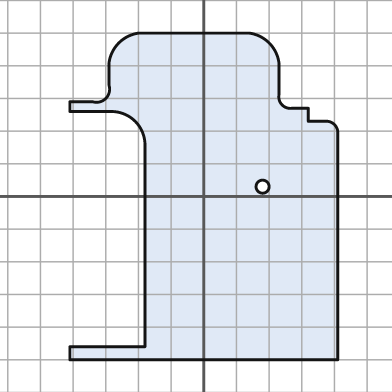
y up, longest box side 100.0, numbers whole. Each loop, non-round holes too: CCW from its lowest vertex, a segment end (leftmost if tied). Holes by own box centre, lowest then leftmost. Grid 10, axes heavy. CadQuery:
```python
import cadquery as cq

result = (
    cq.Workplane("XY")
    .moveTo(-41.0, -50.0)
    .lineTo(41.0, -50.0)
    .lineTo(41.0, 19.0)
    .threePointArc((40.0, 22.0), (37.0, 23.0))
    .lineTo(32.0, 23.0)
    .lineTo(32.0, 27.0)
    .lineTo(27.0, 27.0)
    .threePointArc((24.0, 28.0), (23.0, 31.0))
    .lineTo(23.0, 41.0)
    .threePointArc((20.0, 47.0), (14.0, 50.0))
    .lineTo(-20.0, 50.0)
    .threePointArc((-26.0, 47.0), (-29.0, 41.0))
    .lineTo(-29.0, 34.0)
    .threePointArc((-30.0, 30.0), (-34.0, 29.0))
    .lineTo(-41.0, 29.0)
    .lineTo(-41.0, 26.0)
    .lineTo(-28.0, 26.0)
    .threePointArc((-21.0, 23.0), (-18.0, 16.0))
    .lineTo(-18.0, -46.0)
    .lineTo(-41.0, -46.0)
    .close()
    .moveTo(18.0, 3.0)
    .circle(2.0)
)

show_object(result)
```